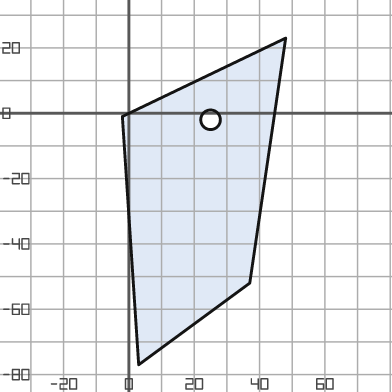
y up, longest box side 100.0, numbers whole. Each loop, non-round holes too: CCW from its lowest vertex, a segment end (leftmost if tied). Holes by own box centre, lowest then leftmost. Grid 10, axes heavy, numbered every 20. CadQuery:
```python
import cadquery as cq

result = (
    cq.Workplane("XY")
    .moveTo(3.0, -77.0)
    .lineTo(37.0, -52.0)
    .lineTo(48.0, 23.0)
    .lineTo(-2.0, -1.0)
    .close()
    .moveTo(25.0, -2.0)
    .circle(3.0)
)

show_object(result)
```